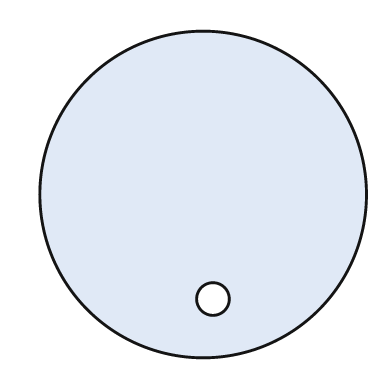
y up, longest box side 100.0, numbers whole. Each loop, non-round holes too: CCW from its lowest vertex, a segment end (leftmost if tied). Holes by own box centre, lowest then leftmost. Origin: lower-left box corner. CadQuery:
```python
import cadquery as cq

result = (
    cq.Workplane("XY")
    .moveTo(50.0, 50.0)
    .circle(50.0)
    .moveTo(53.0, 18.0)
    .circle(5.0)
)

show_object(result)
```